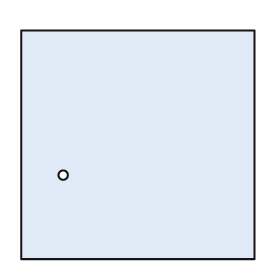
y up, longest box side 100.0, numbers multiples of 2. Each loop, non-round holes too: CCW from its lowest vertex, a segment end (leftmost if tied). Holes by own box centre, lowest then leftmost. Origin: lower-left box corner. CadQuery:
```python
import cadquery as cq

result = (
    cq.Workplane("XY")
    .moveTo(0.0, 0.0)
    .lineTo(100.0, 0.0)
    .lineTo(100.0, 98.0)
    .lineTo(0.0, 98.0)
    .close()
    .moveTo(18.0, 36.0)
    .circle(2.0)
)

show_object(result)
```